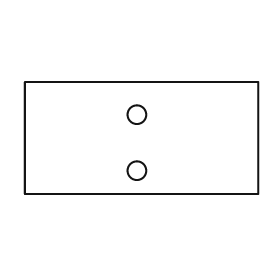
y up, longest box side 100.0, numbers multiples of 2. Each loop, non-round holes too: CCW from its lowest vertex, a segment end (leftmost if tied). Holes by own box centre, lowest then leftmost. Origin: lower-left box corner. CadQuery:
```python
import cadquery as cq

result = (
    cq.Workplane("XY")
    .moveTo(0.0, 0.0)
    .lineTo(100.0, 0.0)
    .lineTo(100.0, 48.0)
    .lineTo(0.0, 48.0)
    .close()
    .moveTo(48.0, 10.0)
    .circle(4.0)
    .moveTo(48.0, 34.0)
    .circle(4.0)
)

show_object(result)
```